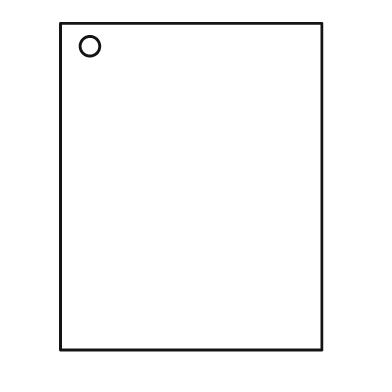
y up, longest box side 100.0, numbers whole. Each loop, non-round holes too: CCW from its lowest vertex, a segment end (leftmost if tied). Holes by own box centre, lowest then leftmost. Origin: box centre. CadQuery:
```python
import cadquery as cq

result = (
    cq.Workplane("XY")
    .moveTo(-40.0, -50.0)
    .lineTo(40.0, -50.0)
    .lineTo(40.0, 50.0)
    .lineTo(-40.0, 50.0)
    .close()
    .moveTo(-31.0, 43.0)
    .circle(3.0)
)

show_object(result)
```